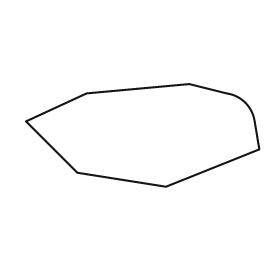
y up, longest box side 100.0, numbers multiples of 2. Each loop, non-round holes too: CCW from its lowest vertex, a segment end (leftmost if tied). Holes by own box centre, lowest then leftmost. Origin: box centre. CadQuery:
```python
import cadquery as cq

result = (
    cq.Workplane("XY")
    .moveTo(10.0, -22.0)
    .lineTo(50.0, -6.0)
    .lineTo(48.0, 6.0)
    .threePointArc((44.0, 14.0), (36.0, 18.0))
    .lineTo(20.0, 22.0)
    .lineTo(-24.0, 18.0)
    .lineTo(-50.0, 6.0)
    .lineTo(-28.0, -16.0)
    .close()
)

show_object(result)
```